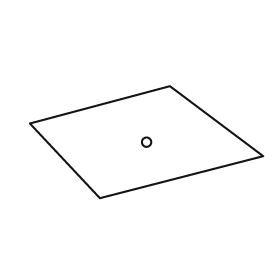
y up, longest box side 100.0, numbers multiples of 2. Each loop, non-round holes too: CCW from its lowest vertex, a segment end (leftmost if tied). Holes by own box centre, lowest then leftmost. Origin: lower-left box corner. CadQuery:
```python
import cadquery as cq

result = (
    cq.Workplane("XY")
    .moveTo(30.0, 0.0)
    .lineTo(100.0, 18.0)
    .lineTo(60.0, 48.0)
    .lineTo(0.0, 32.0)
    .close()
    .moveTo(50.0, 24.0)
    .circle(2.0)
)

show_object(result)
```